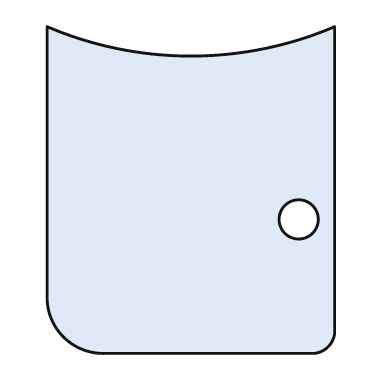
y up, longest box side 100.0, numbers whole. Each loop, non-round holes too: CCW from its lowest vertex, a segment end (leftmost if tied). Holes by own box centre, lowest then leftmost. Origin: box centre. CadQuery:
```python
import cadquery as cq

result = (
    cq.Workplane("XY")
    .moveTo(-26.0, -50.0)
    .lineTo(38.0, -50.0)
    .threePointArc((42.0, -48.0), (44.0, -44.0))
    .lineTo(44.0, 50.0)
    .threePointArc((0.0, 41.0), (-44.0, 50.0))
    .lineTo(-44.0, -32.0)
    .threePointArc((-39.0, -45.0), (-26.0, -50.0))
    .close()
    .moveTo(33.0, -9.0)
    .circle(6.0)
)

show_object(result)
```